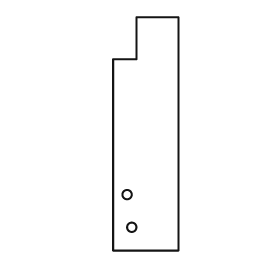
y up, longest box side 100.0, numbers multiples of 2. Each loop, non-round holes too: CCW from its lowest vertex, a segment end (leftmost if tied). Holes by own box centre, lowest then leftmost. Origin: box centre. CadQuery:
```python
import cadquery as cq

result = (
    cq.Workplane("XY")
    .moveTo(-14.0, -50.0)
    .lineTo(14.0, -50.0)
    .lineTo(14.0, 50.0)
    .lineTo(-4.0, 50.0)
    .lineTo(-4.0, 32.0)
    .lineTo(-14.0, 32.0)
    .close()
    .moveTo(-6.0, -40.0)
    .circle(2.0)
    .moveTo(-8.0, -26.0)
    .circle(2.0)
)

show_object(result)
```